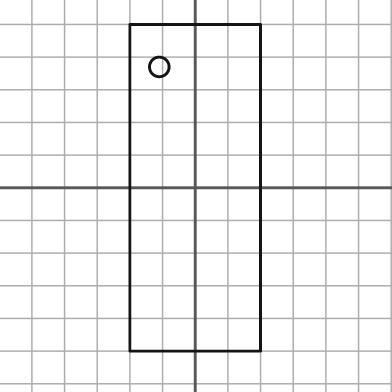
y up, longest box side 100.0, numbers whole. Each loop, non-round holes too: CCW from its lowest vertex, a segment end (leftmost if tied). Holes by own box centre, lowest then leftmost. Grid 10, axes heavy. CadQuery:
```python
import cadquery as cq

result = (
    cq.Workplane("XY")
    .moveTo(-20.0, -50.0)
    .lineTo(20.0, -50.0)
    .lineTo(20.0, 50.0)
    .lineTo(-20.0, 50.0)
    .close()
    .moveTo(-11.0, 37.0)
    .circle(3.0)
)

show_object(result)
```